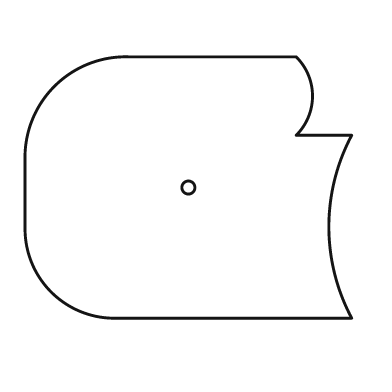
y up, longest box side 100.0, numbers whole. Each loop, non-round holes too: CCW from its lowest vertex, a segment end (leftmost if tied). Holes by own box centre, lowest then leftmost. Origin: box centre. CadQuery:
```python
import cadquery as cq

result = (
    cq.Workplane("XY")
    .moveTo(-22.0, -40.0)
    .lineTo(50.0, -40.0)
    .threePointArc((43.0, -12.0), (50.0, 16.0))
    .lineTo(33.0, 16.0)
    .threePointArc((38.0, 28.0), (33.0, 40.0))
    .lineTo(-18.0, 40.0)
    .threePointArc((-41.0, 31.0), (-50.0, 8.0))
    .lineTo(-50.0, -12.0)
    .threePointArc((-42.0, -32.0), (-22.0, -40.0))
    .close()
    .moveTo(0.0, 0.0)
    .circle(2.0)
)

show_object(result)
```